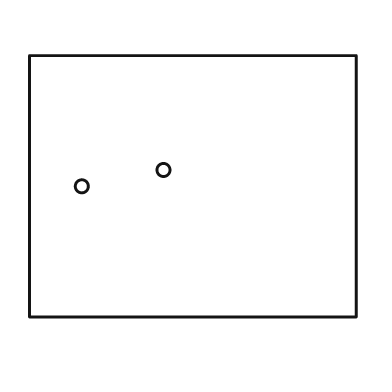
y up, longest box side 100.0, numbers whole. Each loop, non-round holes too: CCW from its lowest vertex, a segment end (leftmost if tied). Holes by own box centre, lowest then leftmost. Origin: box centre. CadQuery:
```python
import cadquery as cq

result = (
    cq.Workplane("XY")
    .moveTo(-50.0, -40.0)
    .lineTo(50.0, -40.0)
    .lineTo(50.0, 40.0)
    .lineTo(-50.0, 40.0)
    .close()
    .moveTo(-34.0, 0.0)
    .circle(2.0)
    .moveTo(-9.0, 5.0)
    .circle(2.0)
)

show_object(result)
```